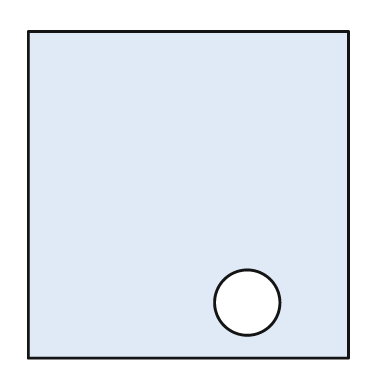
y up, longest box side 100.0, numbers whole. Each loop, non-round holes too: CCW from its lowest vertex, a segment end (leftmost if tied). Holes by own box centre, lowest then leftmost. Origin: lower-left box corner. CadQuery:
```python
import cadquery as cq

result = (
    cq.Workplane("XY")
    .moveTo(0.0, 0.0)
    .lineTo(98.0, 0.0)
    .lineTo(98.0, 100.0)
    .lineTo(0.0, 100.0)
    .close()
    .moveTo(67.0, 17.0)
    .circle(10.0)
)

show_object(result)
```